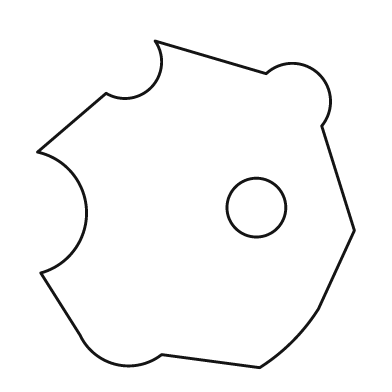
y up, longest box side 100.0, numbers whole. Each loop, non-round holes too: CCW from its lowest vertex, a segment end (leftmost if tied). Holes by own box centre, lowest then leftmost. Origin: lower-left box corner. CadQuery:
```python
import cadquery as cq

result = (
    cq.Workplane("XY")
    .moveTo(68.0, 0.0)
    .threePointArc((78.0, 8.0), (86.0, 18.0))
    .lineTo(97.0, 42.0)
    .lineTo(87.0, 74.0)
    .threePointArc((86.0, 90.0), (70.0, 90.0))
    .lineTo(36.0, 100.0)
    .threePointArc((35.0, 86.0), (21.0, 84.0))
    .lineTo(0.0, 66.0)
    .threePointArc((15.0, 48.0), (1.0, 29.0))
    .lineTo(13.0, 10.0)
    .threePointArc((24.0, 1.0), (38.0, 4.0))
    .close()
    .moveTo(67.0, 49.0)
    .circle(9.0)
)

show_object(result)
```